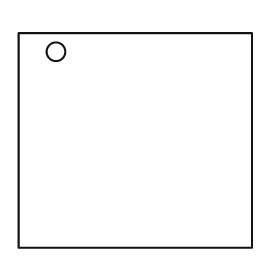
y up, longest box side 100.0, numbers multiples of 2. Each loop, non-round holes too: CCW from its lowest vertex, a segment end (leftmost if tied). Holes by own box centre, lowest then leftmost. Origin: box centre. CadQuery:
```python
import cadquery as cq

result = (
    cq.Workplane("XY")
    .moveTo(-50.0, -46.0)
    .lineTo(50.0, -46.0)
    .lineTo(50.0, 46.0)
    .lineTo(-50.0, 46.0)
    .close()
    .moveTo(-34.0, 38.0)
    .circle(4.0)
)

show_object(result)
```